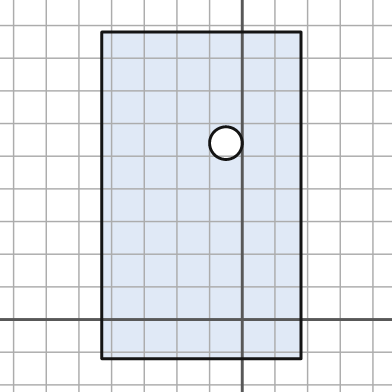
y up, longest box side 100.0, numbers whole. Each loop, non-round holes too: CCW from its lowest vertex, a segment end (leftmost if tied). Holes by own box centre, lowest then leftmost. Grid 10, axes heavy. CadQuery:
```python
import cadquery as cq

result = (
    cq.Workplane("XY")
    .moveTo(-43.0, -12.0)
    .lineTo(18.0, -12.0)
    .lineTo(18.0, 88.0)
    .lineTo(-43.0, 88.0)
    .close()
    .moveTo(-5.0, 54.0)
    .circle(5.0)
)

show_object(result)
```